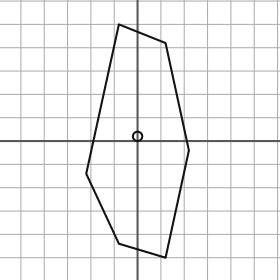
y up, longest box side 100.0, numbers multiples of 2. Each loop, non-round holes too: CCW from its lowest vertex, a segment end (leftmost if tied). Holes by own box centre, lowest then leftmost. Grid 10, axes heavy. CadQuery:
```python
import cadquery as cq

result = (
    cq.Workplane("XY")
    .moveTo(12.0, -50.0)
    .lineTo(22.0, -4.0)
    .lineTo(12.0, 42.0)
    .lineTo(-8.0, 50.0)
    .lineTo(-22.0, -14.0)
    .lineTo(-8.0, -44.0)
    .close()
    .moveTo(0.0, 2.0)
    .circle(2.0)
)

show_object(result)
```